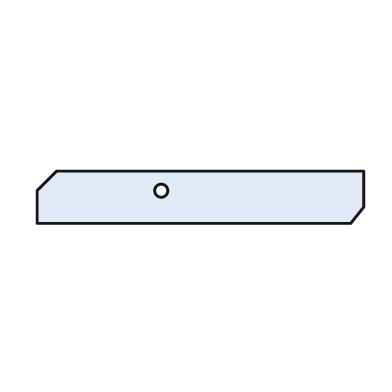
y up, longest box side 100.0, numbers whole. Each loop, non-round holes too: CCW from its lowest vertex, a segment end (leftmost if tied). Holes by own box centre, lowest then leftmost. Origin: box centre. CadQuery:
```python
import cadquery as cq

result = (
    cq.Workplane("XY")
    .moveTo(-50.0, -8.0)
    .lineTo(46.0, -8.0)
    .lineTo(50.0, -3.0)
    .lineTo(50.0, 8.0)
    .lineTo(-44.0, 8.0)
    .lineTo(-50.0, 2.0)
    .close()
    .moveTo(-12.0, 2.0)
    .circle(2.0)
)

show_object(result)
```